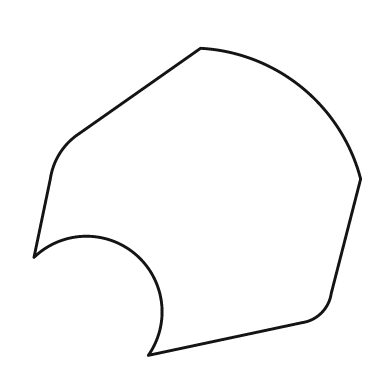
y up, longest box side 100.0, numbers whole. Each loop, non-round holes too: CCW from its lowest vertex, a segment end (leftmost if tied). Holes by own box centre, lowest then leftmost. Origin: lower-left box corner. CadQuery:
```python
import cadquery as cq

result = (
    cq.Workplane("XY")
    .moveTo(35.0, 0.0)
    .lineTo(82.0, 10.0)
    .threePointArc((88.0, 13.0), (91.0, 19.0))
    .lineTo(100.0, 54.0)
    .threePointArc((82.0, 82.0), (51.0, 94.0))
    .lineTo(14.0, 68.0)
    .threePointArc((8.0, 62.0), (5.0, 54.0))
    .lineTo(0.0, 30.0)
    .threePointArc((31.0, 31.0), (35.0, 0.0))
    .close()
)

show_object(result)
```